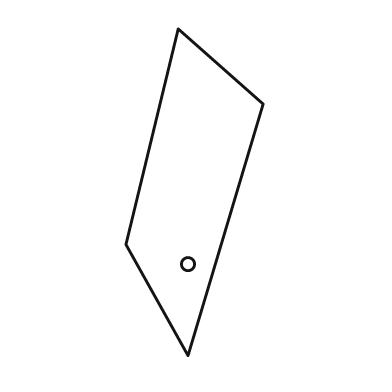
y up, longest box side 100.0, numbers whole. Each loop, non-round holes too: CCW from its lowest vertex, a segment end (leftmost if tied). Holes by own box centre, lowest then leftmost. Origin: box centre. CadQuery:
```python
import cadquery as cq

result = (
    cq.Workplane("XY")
    .moveTo(-2.0, -50.0)
    .lineTo(21.0, 27.0)
    .lineTo(-5.0, 50.0)
    .lineTo(-21.0, -16.0)
    .close()
    .moveTo(-2.0, -22.0)
    .circle(2.0)
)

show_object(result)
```